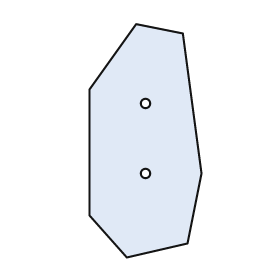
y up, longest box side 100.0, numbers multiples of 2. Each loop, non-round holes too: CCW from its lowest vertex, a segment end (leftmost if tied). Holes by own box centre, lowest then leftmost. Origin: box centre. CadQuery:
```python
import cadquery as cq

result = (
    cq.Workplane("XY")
    .moveTo(-8.0, -50.0)
    .lineTo(18.0, -44.0)
    .lineTo(24.0, -14.0)
    .lineTo(16.0, 46.0)
    .lineTo(-4.0, 50.0)
    .lineTo(-24.0, 22.0)
    .lineTo(-24.0, -32.0)
    .close()
    .moveTo(0.0, -14.0)
    .circle(2.0)
    .moveTo(0.0, 16.0)
    .circle(2.0)
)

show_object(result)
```